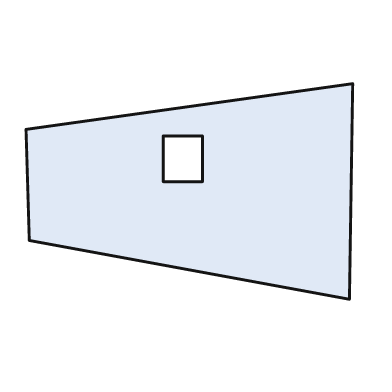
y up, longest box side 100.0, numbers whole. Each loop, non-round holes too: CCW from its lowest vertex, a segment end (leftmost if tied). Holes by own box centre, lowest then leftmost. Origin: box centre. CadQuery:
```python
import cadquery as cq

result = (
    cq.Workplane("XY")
    .moveTo(49.0, -33.0)
    .lineTo(50.0, 33.0)
    .lineTo(-50.0, 19.0)
    .lineTo(-49.0, -15.0)
    .close()
    .moveTo(-8.0, 3.0)
    .lineTo(4.0, 3.0)
    .lineTo(4.0, 17.0)
    .lineTo(-8.0, 17.0)
    .close()
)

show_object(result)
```